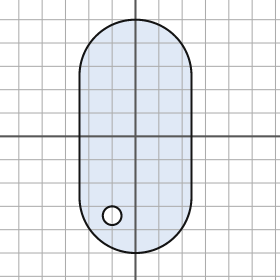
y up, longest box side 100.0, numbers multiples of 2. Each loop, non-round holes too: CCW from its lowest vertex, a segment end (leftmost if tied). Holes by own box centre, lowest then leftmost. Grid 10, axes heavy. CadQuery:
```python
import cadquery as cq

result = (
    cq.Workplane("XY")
    .moveTo(-24.0, -26.0)
    .threePointArc((0.0, -50.0), (24.0, -26.0))
    .lineTo(24.0, 26.0)
    .threePointArc((0.0, 50.0), (-24.0, 26.0))
    .close()
    .moveTo(-10.0, -34.0)
    .circle(4.0)
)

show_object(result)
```